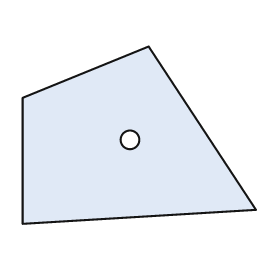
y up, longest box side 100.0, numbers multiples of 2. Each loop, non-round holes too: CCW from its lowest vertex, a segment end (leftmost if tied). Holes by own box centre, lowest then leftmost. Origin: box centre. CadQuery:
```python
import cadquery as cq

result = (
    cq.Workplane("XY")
    .moveTo(-50.0, -38.0)
    .lineTo(50.0, -32.0)
    .lineTo(4.0, 38.0)
    .lineTo(-50.0, 16.0)
    .close()
    .moveTo(-4.0, -2.0)
    .circle(4.0)
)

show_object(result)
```